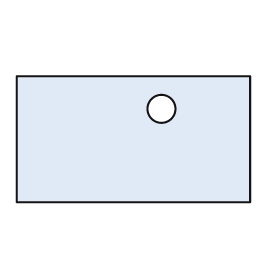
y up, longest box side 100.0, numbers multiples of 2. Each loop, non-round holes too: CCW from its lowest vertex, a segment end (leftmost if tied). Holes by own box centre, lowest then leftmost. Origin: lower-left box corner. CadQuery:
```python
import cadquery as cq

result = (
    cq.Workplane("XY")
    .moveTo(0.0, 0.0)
    .lineTo(100.0, 0.0)
    .lineTo(100.0, 54.0)
    .lineTo(0.0, 54.0)
    .close()
    .moveTo(62.0, 40.0)
    .circle(6.0)
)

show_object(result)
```